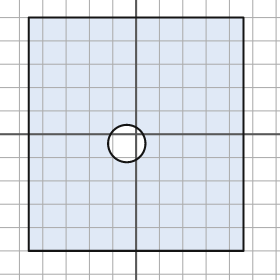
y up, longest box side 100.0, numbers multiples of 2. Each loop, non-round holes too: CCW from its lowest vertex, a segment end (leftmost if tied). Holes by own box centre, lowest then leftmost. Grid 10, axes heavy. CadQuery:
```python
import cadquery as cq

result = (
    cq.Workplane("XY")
    .moveTo(-46.0, -50.0)
    .lineTo(46.0, -50.0)
    .lineTo(46.0, 50.0)
    .lineTo(-46.0, 50.0)
    .close()
    .moveTo(-4.0, -4.0)
    .circle(8.0)
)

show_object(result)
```